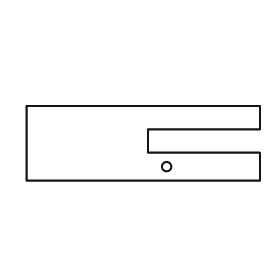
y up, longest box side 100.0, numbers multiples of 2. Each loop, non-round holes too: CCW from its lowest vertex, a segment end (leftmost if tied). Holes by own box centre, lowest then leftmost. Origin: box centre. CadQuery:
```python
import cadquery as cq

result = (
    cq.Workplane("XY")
    .moveTo(-50.0, -16.0)
    .lineTo(50.0, -16.0)
    .lineTo(50.0, -4.0)
    .lineTo(2.0, -4.0)
    .lineTo(2.0, 6.0)
    .lineTo(50.0, 6.0)
    .lineTo(50.0, 16.0)
    .lineTo(-50.0, 16.0)
    .close()
    .moveTo(10.0, -10.0)
    .circle(2.0)
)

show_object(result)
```